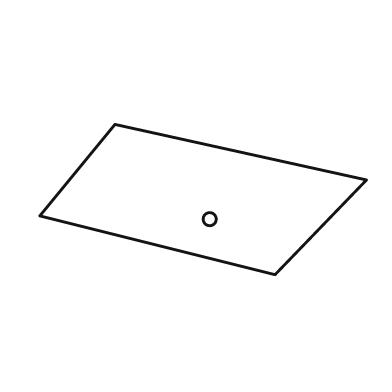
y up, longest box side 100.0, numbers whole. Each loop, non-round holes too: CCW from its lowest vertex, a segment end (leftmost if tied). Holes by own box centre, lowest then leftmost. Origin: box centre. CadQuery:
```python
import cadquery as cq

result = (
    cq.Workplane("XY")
    .moveTo(22.0, -23.0)
    .lineTo(50.0, 6.0)
    .lineTo(-27.0, 23.0)
    .lineTo(-50.0, -5.0)
    .close()
    .moveTo(2.0, -6.0)
    .circle(2.0)
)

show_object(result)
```